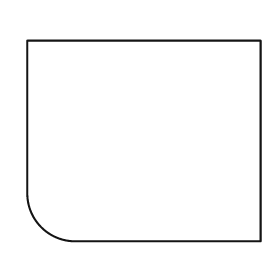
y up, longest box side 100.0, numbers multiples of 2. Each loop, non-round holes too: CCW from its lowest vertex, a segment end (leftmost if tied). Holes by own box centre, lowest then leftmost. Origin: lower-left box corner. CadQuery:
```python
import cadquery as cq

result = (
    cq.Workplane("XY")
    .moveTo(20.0, 0.0)
    .lineTo(100.0, 0.0)
    .lineTo(100.0, 86.0)
    .lineTo(0.0, 86.0)
    .lineTo(0.0, 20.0)
    .threePointArc((6.0, 6.0), (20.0, 0.0))
    .close()
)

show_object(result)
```